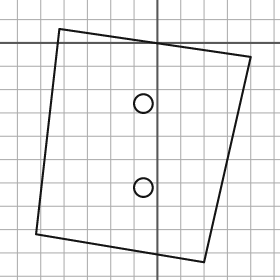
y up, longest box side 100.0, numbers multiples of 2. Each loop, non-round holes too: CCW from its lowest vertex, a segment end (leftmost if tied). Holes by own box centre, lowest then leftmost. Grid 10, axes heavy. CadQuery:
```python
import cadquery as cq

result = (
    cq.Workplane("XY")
    .moveTo(20.0, -94.0)
    .lineTo(40.0, -6.0)
    .lineTo(-42.0, 6.0)
    .lineTo(-52.0, -82.0)
    .close()
    .moveTo(-6.0, -62.0)
    .circle(4.0)
    .moveTo(-6.0, -26.0)
    .circle(4.0)
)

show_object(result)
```